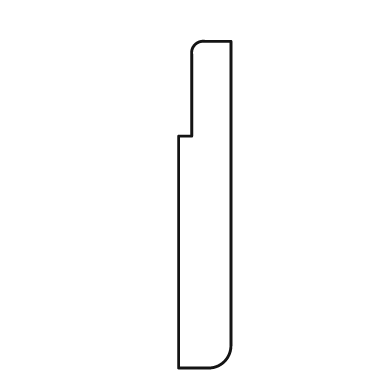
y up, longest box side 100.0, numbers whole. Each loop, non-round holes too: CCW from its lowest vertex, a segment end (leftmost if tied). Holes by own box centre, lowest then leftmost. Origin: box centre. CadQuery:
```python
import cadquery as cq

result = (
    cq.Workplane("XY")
    .moveTo(-8.0, -50.0)
    .lineTo(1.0, -50.0)
    .threePointArc((6.0, -48.0), (8.0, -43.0))
    .lineTo(8.0, 50.0)
    .lineTo(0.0, 50.0)
    .threePointArc((-3.0, 49.0), (-4.0, 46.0))
    .lineTo(-4.0, 21.0)
    .lineTo(-8.0, 21.0)
    .close()
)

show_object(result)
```